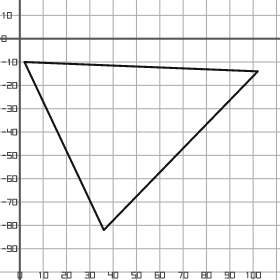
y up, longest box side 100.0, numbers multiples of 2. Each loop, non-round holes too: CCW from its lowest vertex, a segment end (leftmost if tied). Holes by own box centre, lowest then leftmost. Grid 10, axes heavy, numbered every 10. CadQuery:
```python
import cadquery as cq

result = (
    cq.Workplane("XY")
    .moveTo(36.0, -82.0)
    .lineTo(102.0, -14.0)
    .lineTo(2.0, -10.0)
    .close()
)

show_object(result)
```